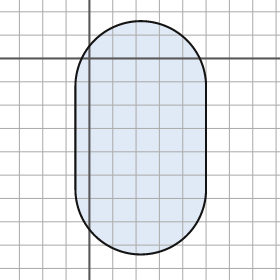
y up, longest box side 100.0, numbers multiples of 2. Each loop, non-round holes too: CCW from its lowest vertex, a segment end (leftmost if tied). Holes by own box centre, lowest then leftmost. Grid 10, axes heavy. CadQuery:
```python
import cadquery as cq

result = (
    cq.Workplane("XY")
    .moveTo(-6.0, -56.0)
    .threePointArc((22.0, -84.0), (50.0, -56.0))
    .lineTo(50.0, -12.0)
    .threePointArc((22.0, 16.0), (-6.0, -12.0))
    .close()
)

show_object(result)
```